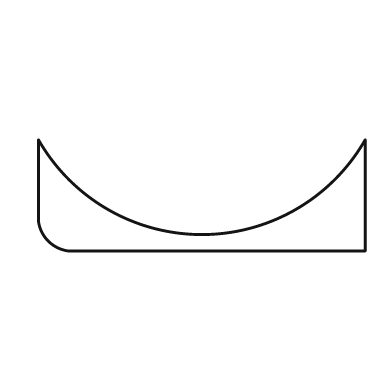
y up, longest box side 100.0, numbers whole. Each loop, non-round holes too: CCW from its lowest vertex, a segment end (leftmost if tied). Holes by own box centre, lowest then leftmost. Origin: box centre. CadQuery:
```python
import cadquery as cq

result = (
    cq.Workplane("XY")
    .moveTo(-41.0, -17.0)
    .lineTo(50.0, -17.0)
    .lineTo(50.0, 17.0)
    .threePointArc((0.0, -12.0), (-50.0, 17.0))
    .lineTo(-50.0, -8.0)
    .threePointArc((-47.0, -14.0), (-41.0, -17.0))
    .close()
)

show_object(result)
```